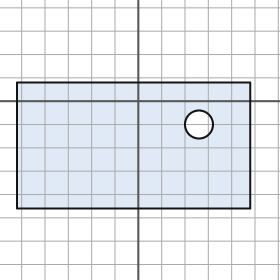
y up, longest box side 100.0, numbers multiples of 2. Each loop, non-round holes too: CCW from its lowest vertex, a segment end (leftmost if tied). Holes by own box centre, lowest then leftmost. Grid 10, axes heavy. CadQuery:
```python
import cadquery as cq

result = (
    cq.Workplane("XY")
    .moveTo(-52.0, -46.0)
    .lineTo(48.0, -46.0)
    .lineTo(48.0, 8.0)
    .lineTo(-52.0, 8.0)
    .close()
    .moveTo(26.0, -10.0)
    .circle(6.0)
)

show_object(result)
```